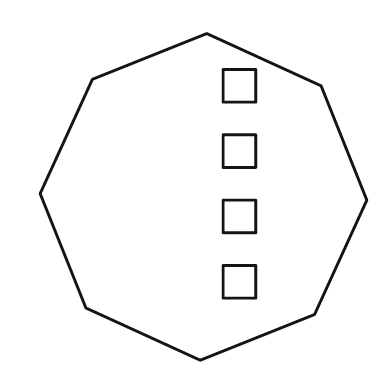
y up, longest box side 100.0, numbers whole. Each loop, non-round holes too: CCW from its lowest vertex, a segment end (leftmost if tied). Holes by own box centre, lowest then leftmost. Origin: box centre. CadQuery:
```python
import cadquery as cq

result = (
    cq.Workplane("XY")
    .moveTo(-1.0, -50.0)
    .lineTo(34.0, -36.0)
    .lineTo(50.0, -1.0)
    .lineTo(36.0, 34.0)
    .lineTo(1.0, 50.0)
    .lineTo(-34.0, 36.0)
    .lineTo(-50.0, 1.0)
    .lineTo(-36.0, -34.0)
    .close()
    .moveTo(6.0, -31.0)
    .lineTo(16.0, -31.0)
    .lineTo(16.0, -21.0)
    .lineTo(6.0, -21.0)
    .close()
    .moveTo(6.0, -11.0)
    .lineTo(16.0, -11.0)
    .lineTo(16.0, -1.0)
    .lineTo(6.0, -1.0)
    .close()
    .moveTo(6.0, 9.0)
    .lineTo(16.0, 9.0)
    .lineTo(16.0, 19.0)
    .lineTo(6.0, 19.0)
    .close()
    .moveTo(6.0, 29.0)
    .lineTo(16.0, 29.0)
    .lineTo(16.0, 39.0)
    .lineTo(6.0, 39.0)
    .close()
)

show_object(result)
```